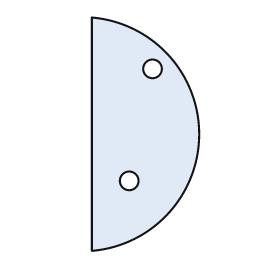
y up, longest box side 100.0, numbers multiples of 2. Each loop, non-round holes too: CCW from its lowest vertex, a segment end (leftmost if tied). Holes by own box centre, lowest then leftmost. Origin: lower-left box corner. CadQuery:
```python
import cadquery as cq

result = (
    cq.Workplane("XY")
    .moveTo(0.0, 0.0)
    .threePointArc((46.0, 50.0), (0.0, 100.0))
    .close()
    .moveTo(16.0, 30.0)
    .circle(4.0)
    .moveTo(26.0, 78.0)
    .circle(4.0)
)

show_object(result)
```